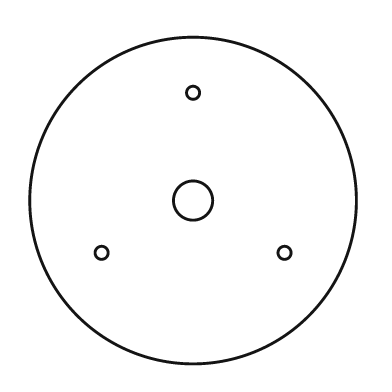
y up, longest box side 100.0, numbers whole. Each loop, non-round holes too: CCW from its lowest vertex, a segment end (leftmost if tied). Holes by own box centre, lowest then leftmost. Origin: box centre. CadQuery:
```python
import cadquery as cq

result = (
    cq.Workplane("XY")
    .moveTo(0.0, 0.0)
    .circle(50.0)
    .moveTo(-28.0, -16.0)
    .circle(2.0)
    .moveTo(28.0, -16.0)
    .circle(2.0)
    .moveTo(0.0, 0.0)
    .circle(6.0)
    .moveTo(0.0, 33.0)
    .circle(2.0)
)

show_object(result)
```